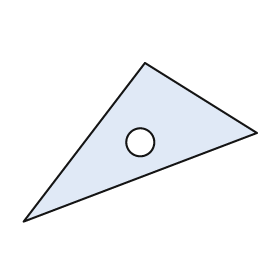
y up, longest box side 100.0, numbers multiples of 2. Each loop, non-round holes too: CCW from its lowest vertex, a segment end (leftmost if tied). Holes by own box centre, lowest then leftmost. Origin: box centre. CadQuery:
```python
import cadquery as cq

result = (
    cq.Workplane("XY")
    .moveTo(-50.0, -34.0)
    .lineTo(50.0, 4.0)
    .lineTo(2.0, 34.0)
    .close()
    .moveTo(0.0, 0.0)
    .circle(6.0)
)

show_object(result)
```